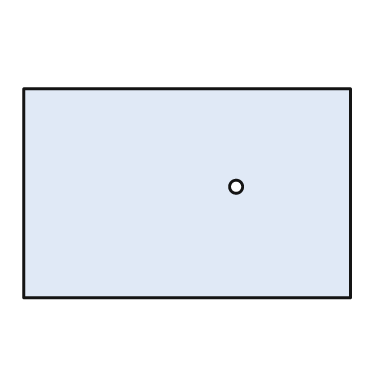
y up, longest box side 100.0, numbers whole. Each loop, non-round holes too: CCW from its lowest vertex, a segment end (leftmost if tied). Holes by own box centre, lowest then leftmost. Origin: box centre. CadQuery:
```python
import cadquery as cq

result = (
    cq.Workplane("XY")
    .moveTo(-50.0, -32.0)
    .lineTo(50.0, -32.0)
    .lineTo(50.0, 32.0)
    .lineTo(-50.0, 32.0)
    .close()
    .moveTo(15.0, 2.0)
    .circle(2.0)
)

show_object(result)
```